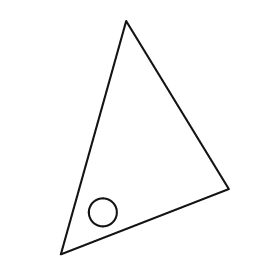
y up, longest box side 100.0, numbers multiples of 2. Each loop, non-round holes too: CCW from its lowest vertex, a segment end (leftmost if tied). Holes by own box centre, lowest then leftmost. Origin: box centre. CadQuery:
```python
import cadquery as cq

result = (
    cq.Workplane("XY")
    .moveTo(-36.0, -50.0)
    .lineTo(36.0, -22.0)
    .lineTo(-8.0, 50.0)
    .close()
    .moveTo(-18.0, -32.0)
    .circle(6.0)
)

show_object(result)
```